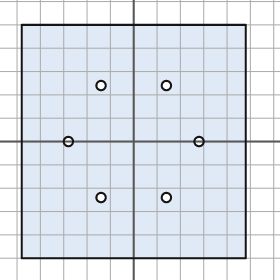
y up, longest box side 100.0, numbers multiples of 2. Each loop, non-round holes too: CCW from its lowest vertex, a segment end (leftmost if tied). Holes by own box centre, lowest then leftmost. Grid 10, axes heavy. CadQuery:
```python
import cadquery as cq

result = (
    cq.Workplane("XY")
    .moveTo(-48.0, -50.0)
    .lineTo(48.0, -50.0)
    .lineTo(48.0, 50.0)
    .lineTo(-48.0, 50.0)
    .close()
    .moveTo(-14.0, -24.0)
    .circle(2.0)
    .moveTo(14.0, -24.0)
    .circle(2.0)
    .moveTo(-28.0, 0.0)
    .circle(2.0)
    .moveTo(28.0, 0.0)
    .circle(2.0)
    .moveTo(-14.0, 24.0)
    .circle(2.0)
    .moveTo(14.0, 24.0)
    .circle(2.0)
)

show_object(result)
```